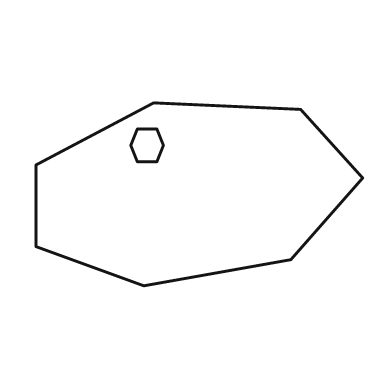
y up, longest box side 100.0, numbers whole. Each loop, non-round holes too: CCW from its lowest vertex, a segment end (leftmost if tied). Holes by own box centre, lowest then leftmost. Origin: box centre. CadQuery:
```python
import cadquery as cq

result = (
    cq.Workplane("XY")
    .moveTo(-17.0, -28.0)
    .lineTo(28.0, -20.0)
    .lineTo(50.0, 5.0)
    .lineTo(31.0, 26.0)
    .lineTo(-14.0, 28.0)
    .lineTo(-50.0, 9.0)
    .lineTo(-50.0, -16.0)
    .close()
    .moveTo(-19.0, 10.0)
    .lineTo(-13.0, 10.0)
    .lineTo(-11.0, 15.0)
    .lineTo(-13.0, 20.0)
    .lineTo(-19.0, 20.0)
    .lineTo(-21.0, 15.0)
    .close()
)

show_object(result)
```